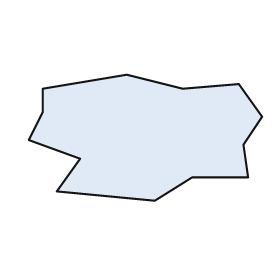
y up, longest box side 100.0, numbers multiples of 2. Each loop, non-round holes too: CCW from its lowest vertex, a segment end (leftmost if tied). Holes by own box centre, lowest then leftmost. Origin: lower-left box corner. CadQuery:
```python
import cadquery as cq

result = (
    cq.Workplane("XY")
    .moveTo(54.0, 0.0)
    .lineTo(70.0, 10.0)
    .lineTo(94.0, 10.0)
    .lineTo(92.0, 24.0)
    .lineTo(100.0, 36.0)
    .lineTo(90.0, 50.0)
    .lineTo(66.0, 48.0)
    .lineTo(42.0, 54.0)
    .lineTo(6.0, 48.0)
    .lineTo(6.0, 38.0)
    .lineTo(0.0, 26.0)
    .lineTo(22.0, 18.0)
    .lineTo(12.0, 4.0)
    .close()
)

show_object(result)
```